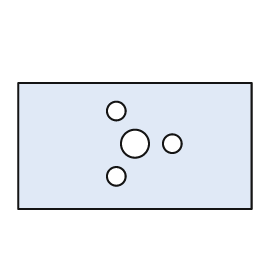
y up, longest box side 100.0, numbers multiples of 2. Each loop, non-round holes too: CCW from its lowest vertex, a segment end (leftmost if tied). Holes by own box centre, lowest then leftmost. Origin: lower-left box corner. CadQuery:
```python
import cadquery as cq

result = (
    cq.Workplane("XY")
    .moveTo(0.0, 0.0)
    .lineTo(100.0, 0.0)
    .lineTo(100.0, 54.0)
    .lineTo(0.0, 54.0)
    .close()
    .moveTo(42.0, 14.0)
    .circle(4.0)
    .moveTo(50.0, 28.0)
    .circle(6.0)
    .moveTo(66.0, 28.0)
    .circle(4.0)
    .moveTo(42.0, 42.0)
    .circle(4.0)
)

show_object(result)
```